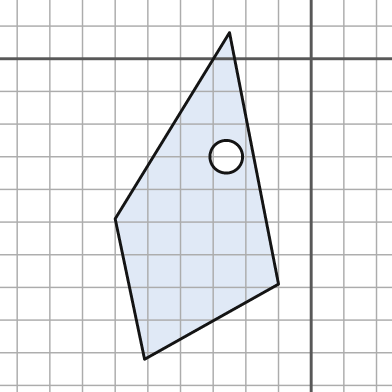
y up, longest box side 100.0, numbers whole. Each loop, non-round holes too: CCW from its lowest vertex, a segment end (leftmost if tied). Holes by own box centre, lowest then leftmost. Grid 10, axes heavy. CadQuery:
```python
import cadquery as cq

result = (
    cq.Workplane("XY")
    .moveTo(-51.0, -92.0)
    .lineTo(-10.0, -69.0)
    .lineTo(-25.0, 8.0)
    .lineTo(-60.0, -49.0)
    .close()
    .moveTo(-26.0, -30.0)
    .circle(5.0)
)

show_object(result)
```